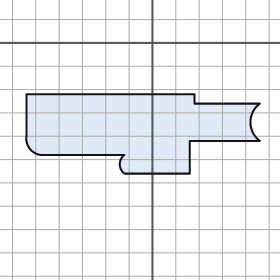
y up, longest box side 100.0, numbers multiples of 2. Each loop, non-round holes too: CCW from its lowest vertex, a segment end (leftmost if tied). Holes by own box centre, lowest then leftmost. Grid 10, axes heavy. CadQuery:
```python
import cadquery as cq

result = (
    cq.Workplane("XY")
    .moveTo(-12.0, -56.0)
    .lineTo(16.0, -56.0)
    .lineTo(16.0, -42.0)
    .lineTo(46.0, -42.0)
    .threePointArc((42.0, -34.0), (46.0, -26.0))
    .lineTo(18.0, -26.0)
    .lineTo(18.0, -22.0)
    .lineTo(-54.0, -22.0)
    .lineTo(-54.0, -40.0)
    .threePointArc((-52.0, -46.0), (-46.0, -48.0))
    .lineTo(-12.0, -48.0)
    .threePointArc((-14.0, -52.0), (-12.0, -56.0))
    .close()
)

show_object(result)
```